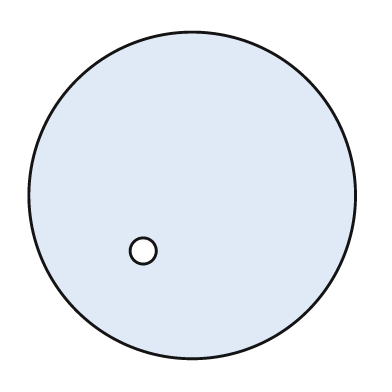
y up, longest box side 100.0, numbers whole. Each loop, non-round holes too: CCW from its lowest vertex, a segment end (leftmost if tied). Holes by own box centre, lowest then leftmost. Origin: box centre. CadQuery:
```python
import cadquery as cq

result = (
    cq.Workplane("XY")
    .moveTo(0.0, 0.0)
    .circle(50.0)
    .moveTo(-15.0, -17.0)
    .circle(4.0)
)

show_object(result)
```